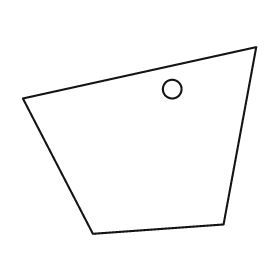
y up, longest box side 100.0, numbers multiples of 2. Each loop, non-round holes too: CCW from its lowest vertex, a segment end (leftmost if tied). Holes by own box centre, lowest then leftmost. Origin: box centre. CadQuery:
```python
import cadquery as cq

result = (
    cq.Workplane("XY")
    .moveTo(-20.0, -40.0)
    .lineTo(36.0, -36.0)
    .lineTo(50.0, 40.0)
    .lineTo(-50.0, 18.0)
    .close()
    .moveTo(14.0, 22.0)
    .circle(4.0)
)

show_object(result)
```